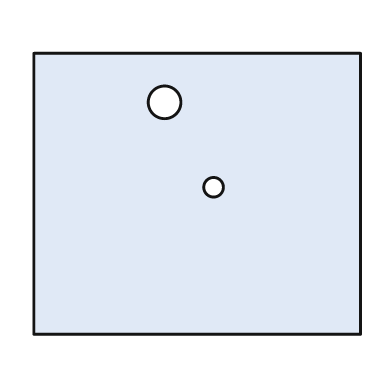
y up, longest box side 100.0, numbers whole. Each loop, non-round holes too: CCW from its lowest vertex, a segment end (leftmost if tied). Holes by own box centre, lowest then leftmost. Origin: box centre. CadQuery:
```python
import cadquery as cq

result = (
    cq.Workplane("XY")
    .moveTo(-50.0, -43.0)
    .lineTo(50.0, -43.0)
    .lineTo(50.0, 43.0)
    .lineTo(-50.0, 43.0)
    .close()
    .moveTo(5.0, 2.0)
    .circle(3.0)
    .moveTo(-10.0, 28.0)
    .circle(5.0)
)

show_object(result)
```